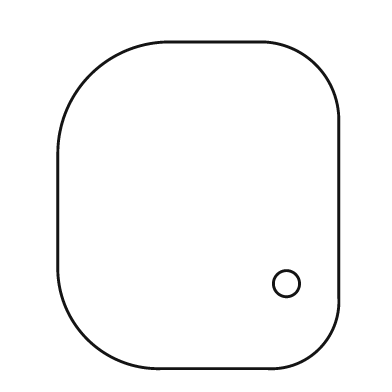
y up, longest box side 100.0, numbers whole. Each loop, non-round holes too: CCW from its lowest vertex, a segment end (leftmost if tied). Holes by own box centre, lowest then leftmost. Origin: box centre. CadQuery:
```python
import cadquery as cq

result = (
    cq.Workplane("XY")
    .moveTo(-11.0, -50.0)
    .lineTo(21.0, -50.0)
    .threePointArc((37.0, -44.0), (43.0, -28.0))
    .lineTo(43.0, 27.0)
    .threePointArc((36.0, 43.0), (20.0, 50.0))
    .lineTo(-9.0, 50.0)
    .threePointArc((-33.0, 40.0), (-43.0, 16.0))
    .lineTo(-43.0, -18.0)
    .threePointArc((-34.0, -41.0), (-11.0, -50.0))
    .close()
    .moveTo(27.0, -24.0)
    .circle(4.0)
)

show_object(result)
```